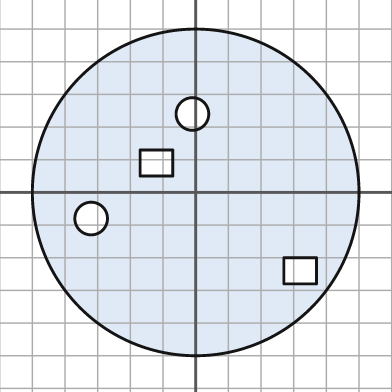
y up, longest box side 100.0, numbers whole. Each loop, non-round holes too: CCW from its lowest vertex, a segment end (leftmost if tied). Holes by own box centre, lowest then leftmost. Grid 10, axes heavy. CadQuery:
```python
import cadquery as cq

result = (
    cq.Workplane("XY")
    .moveTo(0.0, 0.0)
    .circle(50.0)
    .moveTo(27.0, -28.0)
    .lineTo(37.0, -28.0)
    .lineTo(37.0, -20.0)
    .lineTo(27.0, -20.0)
    .close()
    .moveTo(-32.0, -8.0)
    .circle(5.0)
    .moveTo(-17.0, 5.0)
    .lineTo(-7.0, 5.0)
    .lineTo(-7.0, 13.0)
    .lineTo(-17.0, 13.0)
    .close()
    .moveTo(-1.0, 24.0)
    .circle(5.0)
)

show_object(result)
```